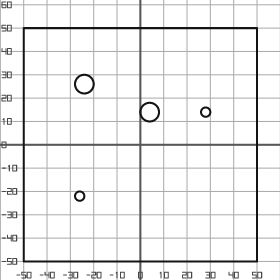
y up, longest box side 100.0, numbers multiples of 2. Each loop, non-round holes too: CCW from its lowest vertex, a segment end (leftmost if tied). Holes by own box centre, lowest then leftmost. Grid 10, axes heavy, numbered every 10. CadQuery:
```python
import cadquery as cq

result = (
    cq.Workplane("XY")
    .moveTo(-50.0, -50.0)
    .lineTo(50.0, -50.0)
    .lineTo(50.0, 50.0)
    .lineTo(-50.0, 50.0)
    .close()
    .moveTo(-26.0, -22.0)
    .circle(2.0)
    .moveTo(4.0, 14.0)
    .circle(4.0)
    .moveTo(28.0, 14.0)
    .circle(2.0)
    .moveTo(-24.0, 26.0)
    .circle(4.0)
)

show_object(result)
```